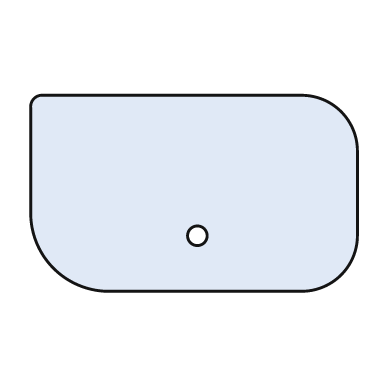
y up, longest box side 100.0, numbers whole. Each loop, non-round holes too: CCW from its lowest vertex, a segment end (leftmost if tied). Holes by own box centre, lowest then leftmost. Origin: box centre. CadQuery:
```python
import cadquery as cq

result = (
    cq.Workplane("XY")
    .moveTo(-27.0, -30.0)
    .lineTo(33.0, -30.0)
    .threePointArc((45.0, -25.0), (50.0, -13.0))
    .lineTo(50.0, 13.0)
    .threePointArc((45.0, 25.0), (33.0, 30.0))
    .lineTo(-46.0, 30.0)
    .threePointArc((-49.0, 29.0), (-50.0, 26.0))
    .lineTo(-50.0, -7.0)
    .threePointArc((-43.0, -23.0), (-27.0, -30.0))
    .close()
    .moveTo(1.0, -13.0)
    .circle(3.0)
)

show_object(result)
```